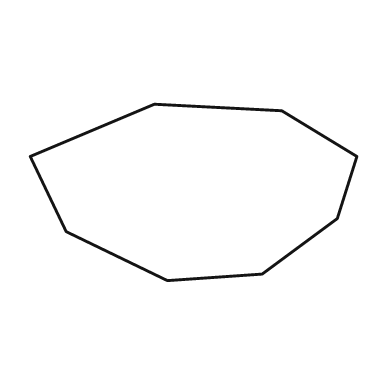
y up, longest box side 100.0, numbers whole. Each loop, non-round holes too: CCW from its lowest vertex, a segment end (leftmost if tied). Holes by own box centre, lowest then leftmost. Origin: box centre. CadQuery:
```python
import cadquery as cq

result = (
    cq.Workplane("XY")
    .moveTo(-8.0, -27.0)
    .lineTo(21.0, -25.0)
    .lineTo(44.0, -8.0)
    .lineTo(50.0, 11.0)
    .lineTo(27.0, 25.0)
    .lineTo(-12.0, 27.0)
    .lineTo(-50.0, 11.0)
    .lineTo(-39.0, -12.0)
    .close()
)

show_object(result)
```